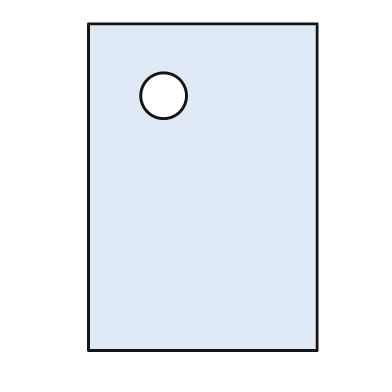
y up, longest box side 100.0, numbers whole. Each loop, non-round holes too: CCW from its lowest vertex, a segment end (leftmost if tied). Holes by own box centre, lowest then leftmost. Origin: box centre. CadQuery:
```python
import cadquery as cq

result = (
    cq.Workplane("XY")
    .moveTo(-35.0, -50.0)
    .lineTo(35.0, -50.0)
    .lineTo(35.0, 50.0)
    .lineTo(-35.0, 50.0)
    .close()
    .moveTo(-12.0, 28.0)
    .circle(7.0)
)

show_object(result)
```